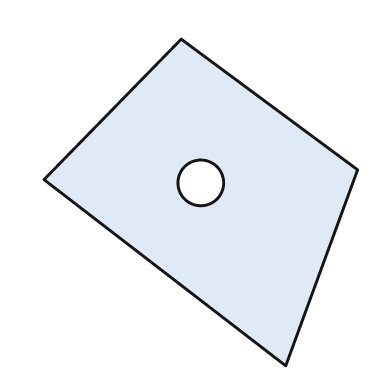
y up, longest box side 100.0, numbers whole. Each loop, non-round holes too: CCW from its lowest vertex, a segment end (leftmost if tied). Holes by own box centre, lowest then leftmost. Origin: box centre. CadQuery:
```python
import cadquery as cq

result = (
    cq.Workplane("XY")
    .moveTo(26.0, -50.0)
    .lineTo(48.0, 10.0)
    .lineTo(-6.0, 50.0)
    .lineTo(-48.0, 7.0)
    .close()
    .moveTo(0.0, 6.0)
    .circle(7.0)
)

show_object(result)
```